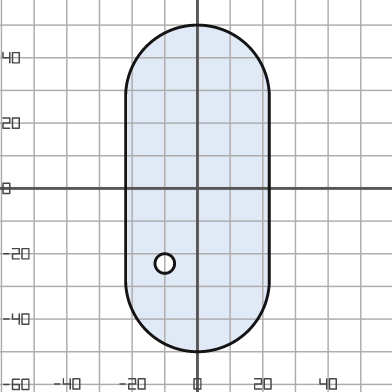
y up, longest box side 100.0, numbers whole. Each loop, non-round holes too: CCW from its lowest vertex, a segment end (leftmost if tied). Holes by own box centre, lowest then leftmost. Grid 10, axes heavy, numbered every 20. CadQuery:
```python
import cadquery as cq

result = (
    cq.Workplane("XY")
    .moveTo(-22.0, -28.0)
    .threePointArc((0.0, -50.0), (22.0, -28.0))
    .lineTo(22.0, 28.0)
    .threePointArc((0.0, 50.0), (-22.0, 28.0))
    .close()
    .moveTo(-10.0, -23.0)
    .circle(3.0)
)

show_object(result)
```